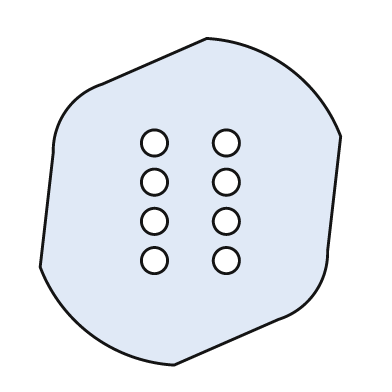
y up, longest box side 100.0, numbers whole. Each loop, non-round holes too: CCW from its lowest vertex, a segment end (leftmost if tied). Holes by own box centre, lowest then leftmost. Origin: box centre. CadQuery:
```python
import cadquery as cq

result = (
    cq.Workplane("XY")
    .moveTo(-5.0, -50.0)
    .lineTo(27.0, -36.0)
    .threePointArc((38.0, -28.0), (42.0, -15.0))
    .lineTo(46.0, 20.0)
    .threePointArc((30.0, 41.0), (5.0, 50.0))
    .lineTo(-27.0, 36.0)
    .threePointArc((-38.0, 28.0), (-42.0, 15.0))
    .lineTo(-46.0, -20.0)
    .threePointArc((-30.0, -41.0), (-5.0, -50.0))
    .close()
    .moveTo(-11.0, -18.0)
    .circle(4.0)
    .moveTo(11.0, -18.0)
    .circle(4.0)
    .moveTo(-11.0, -6.0)
    .circle(4.0)
    .moveTo(11.0, -6.0)
    .circle(4.0)
    .moveTo(-11.0, 6.0)
    .circle(4.0)
    .moveTo(11.0, 6.0)
    .circle(4.0)
    .moveTo(-11.0, 18.0)
    .circle(4.0)
    .moveTo(11.0, 18.0)
    .circle(4.0)
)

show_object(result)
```